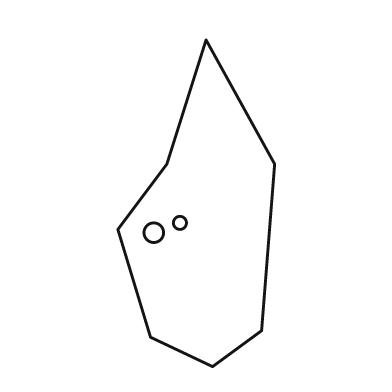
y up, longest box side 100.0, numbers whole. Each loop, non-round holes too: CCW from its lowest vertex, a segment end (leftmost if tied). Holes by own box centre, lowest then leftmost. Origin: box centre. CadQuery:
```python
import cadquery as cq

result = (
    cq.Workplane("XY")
    .moveTo(5.0, -50.0)
    .lineTo(20.0, -39.0)
    .lineTo(24.0, 12.0)
    .lineTo(3.0, 50.0)
    .lineTo(-9.0, 12.0)
    .lineTo(-24.0, -8.0)
    .lineTo(-14.0, -41.0)
    .close()
    .moveTo(-13.0, -9.0)
    .circle(3.0)
    .moveTo(-5.0, -6.0)
    .circle(2.0)
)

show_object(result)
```